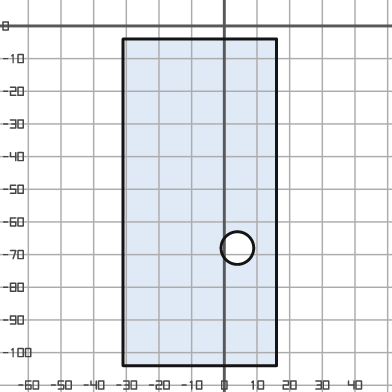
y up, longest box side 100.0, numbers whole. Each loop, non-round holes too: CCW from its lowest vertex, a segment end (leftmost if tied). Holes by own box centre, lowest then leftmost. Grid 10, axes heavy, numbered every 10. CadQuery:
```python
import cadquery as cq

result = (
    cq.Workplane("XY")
    .moveTo(-31.0, -104.0)
    .lineTo(16.0, -104.0)
    .lineTo(16.0, -4.0)
    .lineTo(-31.0, -4.0)
    .close()
    .moveTo(4.0, -68.0)
    .circle(5.0)
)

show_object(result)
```